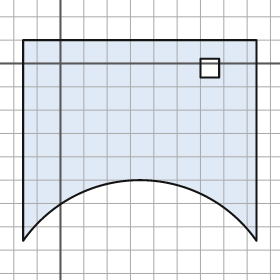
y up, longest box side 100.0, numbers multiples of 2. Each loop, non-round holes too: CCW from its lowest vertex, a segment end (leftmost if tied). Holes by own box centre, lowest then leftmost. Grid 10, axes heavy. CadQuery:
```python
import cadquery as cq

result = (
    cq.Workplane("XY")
    .moveTo(-16.0, -76.0)
    .threePointArc((34.0, -50.0), (84.0, -76.0))
    .lineTo(84.0, 10.0)
    .lineTo(-16.0, 10.0)
    .close()
    .moveTo(60.0, -6.0)
    .lineTo(68.0, -6.0)
    .lineTo(68.0, 2.0)
    .lineTo(60.0, 2.0)
    .close()
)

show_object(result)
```